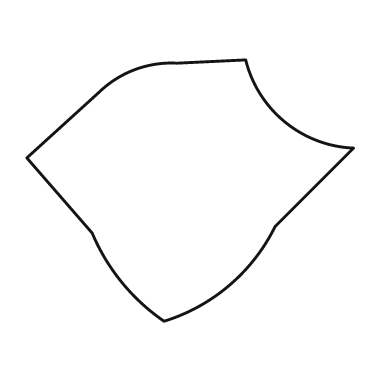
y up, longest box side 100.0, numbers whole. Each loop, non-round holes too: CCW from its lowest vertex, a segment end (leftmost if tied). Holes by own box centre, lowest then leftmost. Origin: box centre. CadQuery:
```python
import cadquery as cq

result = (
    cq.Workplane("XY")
    .moveTo(-8.0, -40.0)
    .threePointArc((12.0, -29.0), (26.0, -11.0))
    .lineTo(50.0, 13.0)
    .threePointArc((29.0, 21.0), (17.0, 40.0))
    .lineTo(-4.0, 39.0)
    .threePointArc((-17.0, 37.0), (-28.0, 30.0))
    .lineTo(-50.0, 10.0)
    .lineTo(-30.0, -13.0)
    .threePointArc((-21.0, -28.0), (-8.0, -40.0))
    .close()
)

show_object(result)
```